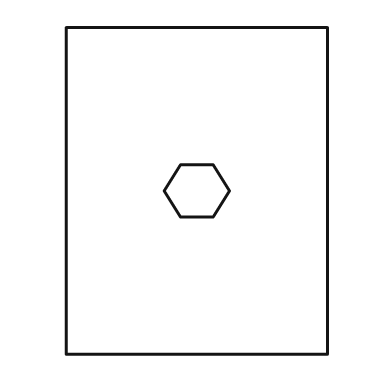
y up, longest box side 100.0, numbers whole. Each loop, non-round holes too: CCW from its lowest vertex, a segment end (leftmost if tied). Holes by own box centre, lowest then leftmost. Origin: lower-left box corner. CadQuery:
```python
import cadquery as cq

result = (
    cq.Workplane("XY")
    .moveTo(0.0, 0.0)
    .lineTo(80.0, 0.0)
    .lineTo(80.0, 100.0)
    .lineTo(0.0, 100.0)
    .close()
    .moveTo(35.0, 42.0)
    .lineTo(45.0, 42.0)
    .lineTo(50.0, 50.0)
    .lineTo(45.0, 58.0)
    .lineTo(35.0, 58.0)
    .lineTo(30.0, 50.0)
    .close()
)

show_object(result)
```